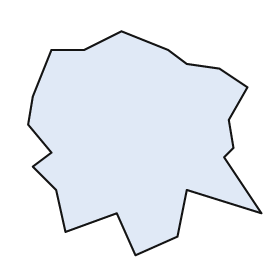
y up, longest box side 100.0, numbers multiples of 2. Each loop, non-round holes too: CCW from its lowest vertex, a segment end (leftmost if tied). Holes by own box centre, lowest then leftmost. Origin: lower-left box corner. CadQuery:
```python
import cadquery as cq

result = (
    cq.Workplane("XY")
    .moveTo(46.0, 0.0)
    .lineTo(64.0, 8.0)
    .lineTo(68.0, 28.0)
    .lineTo(100.0, 18.0)
    .lineTo(84.0, 42.0)
    .lineTo(88.0, 46.0)
    .lineTo(86.0, 58.0)
    .lineTo(94.0, 72.0)
    .lineTo(82.0, 80.0)
    .lineTo(68.0, 82.0)
    .lineTo(60.0, 88.0)
    .lineTo(40.0, 96.0)
    .lineTo(24.0, 88.0)
    .lineTo(10.0, 88.0)
    .lineTo(2.0, 68.0)
    .lineTo(0.0, 56.0)
    .lineTo(10.0, 44.0)
    .lineTo(2.0, 38.0)
    .lineTo(12.0, 28.0)
    .lineTo(16.0, 10.0)
    .lineTo(38.0, 18.0)
    .close()
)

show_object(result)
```